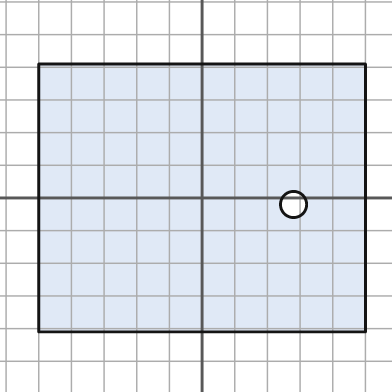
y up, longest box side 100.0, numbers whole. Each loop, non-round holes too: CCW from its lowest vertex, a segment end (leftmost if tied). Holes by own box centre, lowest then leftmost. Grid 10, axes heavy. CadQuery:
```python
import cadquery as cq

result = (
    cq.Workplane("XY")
    .moveTo(-50.0, -41.0)
    .lineTo(50.0, -41.0)
    .lineTo(50.0, 41.0)
    .lineTo(-50.0, 41.0)
    .close()
    .moveTo(28.0, -2.0)
    .circle(4.0)
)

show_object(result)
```